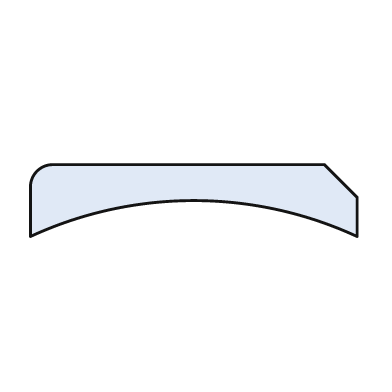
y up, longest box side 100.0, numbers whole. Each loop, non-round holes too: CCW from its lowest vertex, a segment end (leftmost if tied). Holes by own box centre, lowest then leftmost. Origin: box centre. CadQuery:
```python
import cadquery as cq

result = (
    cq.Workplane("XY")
    .moveTo(-50.0, -11.0)
    .threePointArc((0.0, 0.0), (50.0, -11.0))
    .lineTo(50.0, 1.0)
    .lineTo(40.0, 11.0)
    .lineTo(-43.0, 11.0)
    .threePointArc((-48.0, 9.0), (-50.0, 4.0))
    .close()
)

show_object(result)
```